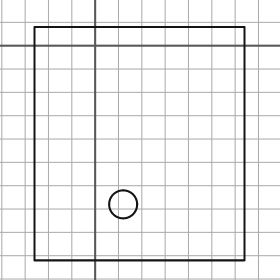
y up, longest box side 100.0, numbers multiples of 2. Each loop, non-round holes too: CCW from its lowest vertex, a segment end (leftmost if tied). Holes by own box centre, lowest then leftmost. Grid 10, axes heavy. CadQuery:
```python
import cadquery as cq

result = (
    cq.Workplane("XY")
    .moveTo(-26.0, -92.0)
    .lineTo(64.0, -92.0)
    .lineTo(64.0, 8.0)
    .lineTo(-26.0, 8.0)
    .close()
    .moveTo(12.0, -68.0)
    .circle(6.0)
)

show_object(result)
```